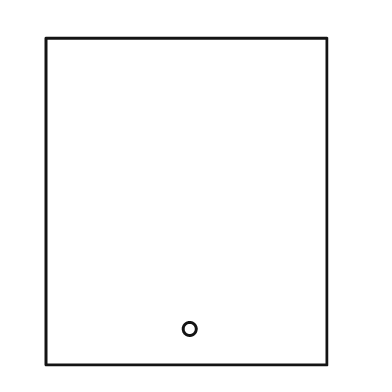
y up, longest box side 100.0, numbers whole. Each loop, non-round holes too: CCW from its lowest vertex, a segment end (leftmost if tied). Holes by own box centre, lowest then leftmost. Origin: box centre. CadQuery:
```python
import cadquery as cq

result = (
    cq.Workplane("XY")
    .moveTo(-43.0, -50.0)
    .lineTo(43.0, -50.0)
    .lineTo(43.0, 50.0)
    .lineTo(-43.0, 50.0)
    .close()
    .moveTo(1.0, -39.0)
    .circle(2.0)
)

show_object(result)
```